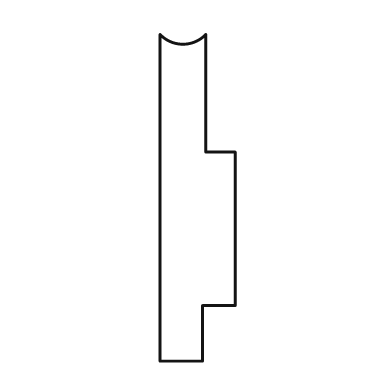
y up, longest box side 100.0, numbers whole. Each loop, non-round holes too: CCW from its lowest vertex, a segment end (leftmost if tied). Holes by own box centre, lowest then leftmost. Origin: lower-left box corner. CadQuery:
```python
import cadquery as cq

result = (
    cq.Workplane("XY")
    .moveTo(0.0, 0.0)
    .lineTo(13.0, 0.0)
    .lineTo(13.0, 17.0)
    .lineTo(23.0, 17.0)
    .lineTo(23.0, 64.0)
    .lineTo(14.0, 64.0)
    .lineTo(14.0, 100.0)
    .threePointArc((7.0, 97.0), (0.0, 100.0))
    .close()
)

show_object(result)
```